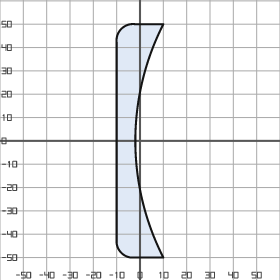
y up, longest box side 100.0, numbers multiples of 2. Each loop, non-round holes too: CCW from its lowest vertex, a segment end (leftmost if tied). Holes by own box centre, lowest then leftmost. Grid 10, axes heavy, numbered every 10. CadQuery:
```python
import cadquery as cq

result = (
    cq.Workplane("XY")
    .moveTo(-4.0, -50.0)
    .lineTo(10.0, -50.0)
    .threePointArc((-2.0, 0.0), (10.0, 50.0))
    .lineTo(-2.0, 50.0)
    .threePointArc((-8.0, 48.0), (-10.0, 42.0))
    .lineTo(-10.0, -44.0)
    .threePointArc((-8.0, -48.0), (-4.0, -50.0))
    .close()
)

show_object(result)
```